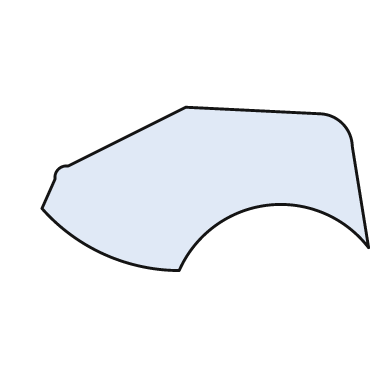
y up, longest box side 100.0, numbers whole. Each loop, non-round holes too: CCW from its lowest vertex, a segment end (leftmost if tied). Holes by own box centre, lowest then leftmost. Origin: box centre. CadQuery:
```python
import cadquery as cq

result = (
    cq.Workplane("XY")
    .moveTo(-8.0, -25.0)
    .threePointArc((19.0, -5.0), (50.0, -18.0))
    .lineTo(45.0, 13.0)
    .threePointArc((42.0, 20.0), (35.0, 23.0))
    .lineTo(-6.0, 25.0)
    .lineTo(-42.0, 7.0)
    .threePointArc((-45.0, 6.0), (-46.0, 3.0))
    .lineTo(-50.0, -6.0)
    .threePointArc((-31.0, -20.0), (-8.0, -25.0))
    .close()
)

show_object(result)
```